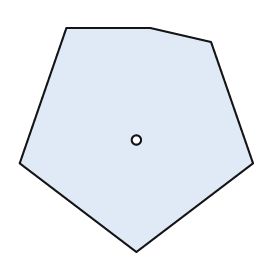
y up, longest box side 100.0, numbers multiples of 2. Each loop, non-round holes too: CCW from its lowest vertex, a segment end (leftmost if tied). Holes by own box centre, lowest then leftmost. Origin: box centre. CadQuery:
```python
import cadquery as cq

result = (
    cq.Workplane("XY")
    .moveTo(0.0, -48.0)
    .lineTo(50.0, -10.0)
    .lineTo(32.0, 42.0)
    .lineTo(6.0, 48.0)
    .lineTo(-30.0, 48.0)
    .lineTo(-50.0, -10.0)
    .close()
    .moveTo(0.0, 0.0)
    .circle(2.0)
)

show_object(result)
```